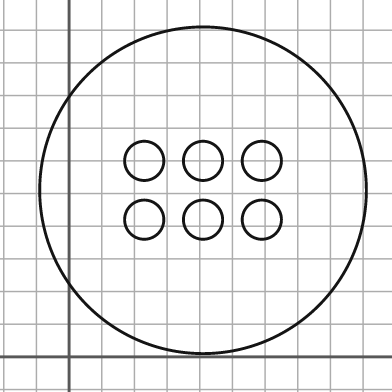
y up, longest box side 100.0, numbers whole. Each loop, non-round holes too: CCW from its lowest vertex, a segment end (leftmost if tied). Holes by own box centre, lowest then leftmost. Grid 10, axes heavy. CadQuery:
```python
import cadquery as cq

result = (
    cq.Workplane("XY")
    .moveTo(41.0, 51.0)
    .circle(50.0)
    .moveTo(23.0, 42.0)
    .circle(6.0)
    .moveTo(41.0, 42.0)
    .circle(6.0)
    .moveTo(59.0, 42.0)
    .circle(6.0)
    .moveTo(23.0, 60.0)
    .circle(6.0)
    .moveTo(41.0, 60.0)
    .circle(6.0)
    .moveTo(59.0, 60.0)
    .circle(6.0)
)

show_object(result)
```